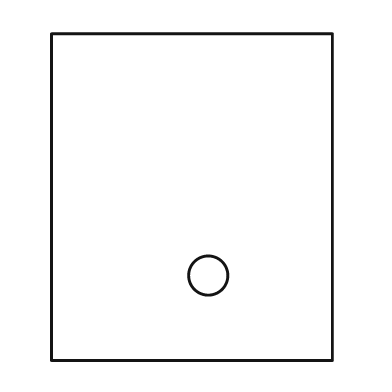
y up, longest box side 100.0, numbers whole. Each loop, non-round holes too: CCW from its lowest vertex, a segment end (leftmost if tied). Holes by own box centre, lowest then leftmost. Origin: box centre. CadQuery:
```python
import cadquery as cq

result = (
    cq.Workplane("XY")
    .moveTo(-43.0, -50.0)
    .lineTo(43.0, -50.0)
    .lineTo(43.0, 50.0)
    .lineTo(-43.0, 50.0)
    .close()
    .moveTo(5.0, -24.0)
    .circle(6.0)
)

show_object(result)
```